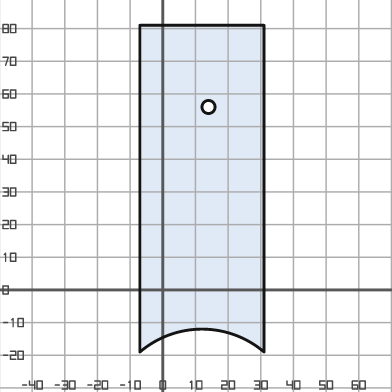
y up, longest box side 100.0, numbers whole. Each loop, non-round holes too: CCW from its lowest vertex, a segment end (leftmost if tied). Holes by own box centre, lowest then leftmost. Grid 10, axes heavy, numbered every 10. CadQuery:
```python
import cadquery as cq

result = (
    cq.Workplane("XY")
    .moveTo(-7.0, -19.0)
    .threePointArc((12.0, -12.0), (31.0, -19.0))
    .lineTo(31.0, 81.0)
    .lineTo(-7.0, 81.0)
    .close()
    .moveTo(14.0, 56.0)
    .circle(2.0)
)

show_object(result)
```